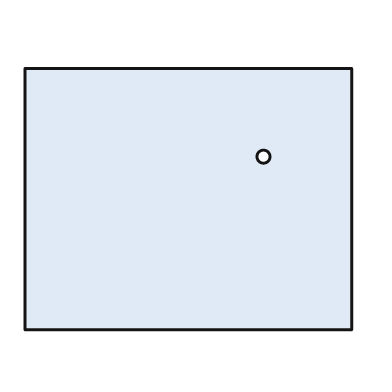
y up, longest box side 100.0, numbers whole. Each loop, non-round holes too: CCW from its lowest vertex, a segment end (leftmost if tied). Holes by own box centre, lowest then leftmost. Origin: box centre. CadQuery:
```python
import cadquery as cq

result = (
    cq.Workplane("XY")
    .moveTo(-50.0, -40.0)
    .lineTo(50.0, -40.0)
    .lineTo(50.0, 40.0)
    .lineTo(-50.0, 40.0)
    .close()
    .moveTo(23.0, 13.0)
    .circle(2.0)
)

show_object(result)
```